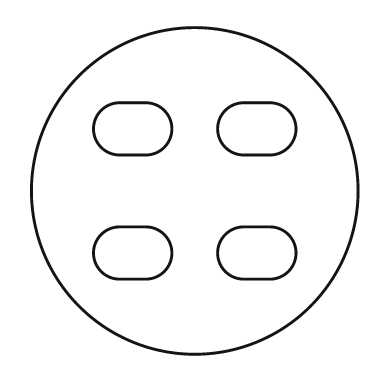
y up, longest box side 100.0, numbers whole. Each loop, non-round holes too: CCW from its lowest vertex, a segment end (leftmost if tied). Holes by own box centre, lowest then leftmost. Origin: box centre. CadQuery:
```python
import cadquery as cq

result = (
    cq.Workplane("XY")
    .moveTo(0.0, 0.0)
    .circle(50.0)
    .moveTo(-23.0, -27.0)
    .lineTo(-15.0, -27.0)
    .threePointArc((-7.0, -19.0), (-15.0, -11.0))
    .lineTo(-23.0, -11.0)
    .threePointArc((-31.0, -19.0), (-23.0, -27.0))
    .close()
    .moveTo(15.0, -27.0)
    .lineTo(23.0, -27.0)
    .threePointArc((31.0, -19.0), (23.0, -11.0))
    .lineTo(15.0, -11.0)
    .threePointArc((7.0, -19.0), (15.0, -27.0))
    .close()
    .moveTo(-23.0, 11.0)
    .lineTo(-15.0, 11.0)
    .threePointArc((-7.0, 19.0), (-15.0, 27.0))
    .lineTo(-23.0, 27.0)
    .threePointArc((-31.0, 19.0), (-23.0, 11.0))
    .close()
    .moveTo(15.0, 11.0)
    .lineTo(23.0, 11.0)
    .threePointArc((31.0, 19.0), (23.0, 27.0))
    .lineTo(15.0, 27.0)
    .threePointArc((7.0, 19.0), (15.0, 11.0))
    .close()
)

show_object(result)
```